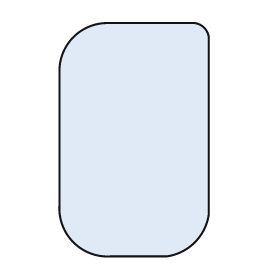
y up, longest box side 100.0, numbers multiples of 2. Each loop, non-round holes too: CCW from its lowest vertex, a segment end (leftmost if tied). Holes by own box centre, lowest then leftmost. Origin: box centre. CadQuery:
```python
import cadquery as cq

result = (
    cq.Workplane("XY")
    .moveTo(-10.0, -50.0)
    .lineTo(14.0, -50.0)
    .threePointArc((26.0, -44.0), (32.0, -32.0))
    .lineTo(32.0, 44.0)
    .threePointArc((30.0, 48.0), (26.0, 50.0))
    .lineTo(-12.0, 50.0)
    .threePointArc((-26.0, 44.0), (-32.0, 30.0))
    .lineTo(-32.0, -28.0)
    .threePointArc((-26.0, -44.0), (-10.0, -50.0))
    .close()
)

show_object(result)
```